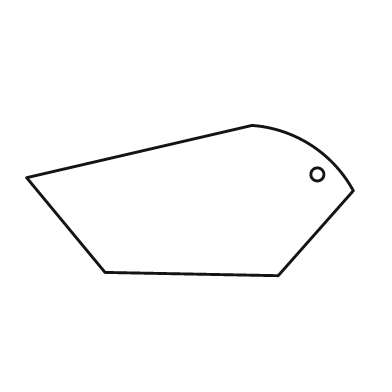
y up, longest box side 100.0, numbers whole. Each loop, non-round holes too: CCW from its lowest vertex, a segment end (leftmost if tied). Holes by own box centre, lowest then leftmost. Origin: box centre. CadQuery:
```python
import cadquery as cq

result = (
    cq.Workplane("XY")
    .moveTo(27.0, -23.0)
    .lineTo(50.0, 3.0)
    .threePointArc((37.0, 17.0), (19.0, 23.0))
    .lineTo(-50.0, 7.0)
    .lineTo(-26.0, -22.0)
    .close()
    .moveTo(39.0, 8.0)
    .circle(2.0)
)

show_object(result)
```